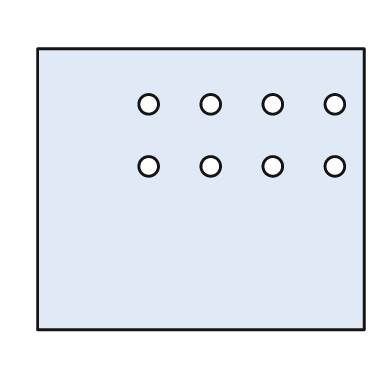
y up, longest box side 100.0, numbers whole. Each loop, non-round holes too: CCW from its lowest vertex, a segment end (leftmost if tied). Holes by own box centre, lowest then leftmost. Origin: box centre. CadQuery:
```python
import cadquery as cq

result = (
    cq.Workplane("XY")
    .moveTo(-50.0, -43.0)
    .lineTo(50.0, -43.0)
    .lineTo(50.0, 43.0)
    .lineTo(-50.0, 43.0)
    .close()
    .moveTo(-16.0, 7.0)
    .circle(3.0)
    .moveTo(3.0, 7.0)
    .circle(3.0)
    .moveTo(22.0, 7.0)
    .circle(3.0)
    .moveTo(41.0, 7.0)
    .circle(3.0)
    .moveTo(-16.0, 26.0)
    .circle(3.0)
    .moveTo(3.0, 26.0)
    .circle(3.0)
    .moveTo(22.0, 26.0)
    .circle(3.0)
    .moveTo(41.0, 26.0)
    .circle(3.0)
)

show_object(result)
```